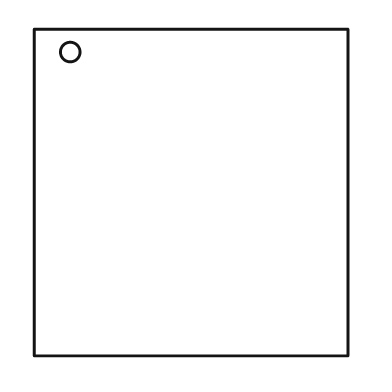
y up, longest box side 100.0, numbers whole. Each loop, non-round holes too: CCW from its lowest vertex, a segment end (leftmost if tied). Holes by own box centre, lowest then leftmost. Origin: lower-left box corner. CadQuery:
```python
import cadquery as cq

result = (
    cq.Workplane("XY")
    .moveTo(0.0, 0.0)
    .lineTo(96.0, 0.0)
    .lineTo(96.0, 100.0)
    .lineTo(0.0, 100.0)
    .close()
    .moveTo(11.0, 93.0)
    .circle(3.0)
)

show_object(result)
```